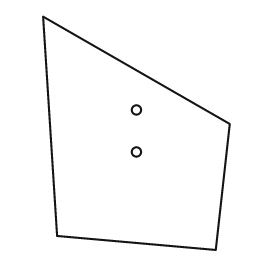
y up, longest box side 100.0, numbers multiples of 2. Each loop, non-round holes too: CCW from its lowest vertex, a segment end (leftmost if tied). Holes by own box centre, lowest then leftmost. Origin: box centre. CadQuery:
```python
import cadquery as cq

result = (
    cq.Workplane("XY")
    .moveTo(34.0, -50.0)
    .lineTo(40.0, 4.0)
    .lineTo(-40.0, 50.0)
    .lineTo(-34.0, -44.0)
    .close()
    .moveTo(0.0, -8.0)
    .circle(2.0)
    .moveTo(0.0, 10.0)
    .circle(2.0)
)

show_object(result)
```